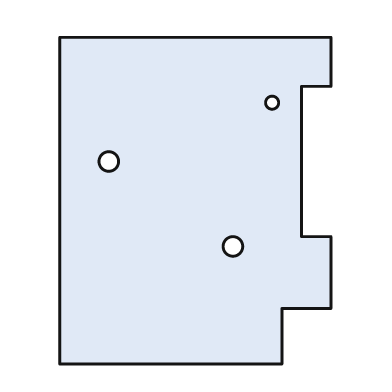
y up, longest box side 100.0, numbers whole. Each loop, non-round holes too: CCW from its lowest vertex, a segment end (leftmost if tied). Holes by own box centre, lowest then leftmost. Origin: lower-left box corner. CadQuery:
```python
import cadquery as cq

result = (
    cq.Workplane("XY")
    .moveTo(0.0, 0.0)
    .lineTo(68.0, 0.0)
    .lineTo(68.0, 17.0)
    .lineTo(83.0, 17.0)
    .lineTo(83.0, 39.0)
    .lineTo(74.0, 39.0)
    .lineTo(74.0, 85.0)
    .lineTo(83.0, 85.0)
    .lineTo(83.0, 100.0)
    .lineTo(0.0, 100.0)
    .close()
    .moveTo(53.0, 36.0)
    .circle(3.0)
    .moveTo(15.0, 62.0)
    .circle(3.0)
    .moveTo(65.0, 80.0)
    .circle(2.0)
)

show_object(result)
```